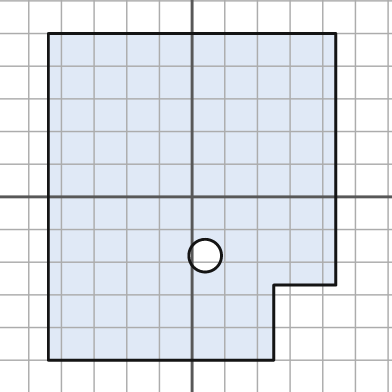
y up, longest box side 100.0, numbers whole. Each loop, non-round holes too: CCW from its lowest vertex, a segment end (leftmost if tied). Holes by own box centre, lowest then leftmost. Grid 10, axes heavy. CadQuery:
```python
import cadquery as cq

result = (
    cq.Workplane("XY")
    .moveTo(-44.0, -50.0)
    .lineTo(25.0, -50.0)
    .lineTo(25.0, -27.0)
    .lineTo(44.0, -27.0)
    .lineTo(44.0, 50.0)
    .lineTo(-44.0, 50.0)
    .close()
    .moveTo(4.0, -18.0)
    .circle(5.0)
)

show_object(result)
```